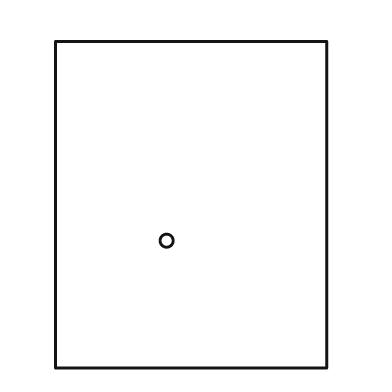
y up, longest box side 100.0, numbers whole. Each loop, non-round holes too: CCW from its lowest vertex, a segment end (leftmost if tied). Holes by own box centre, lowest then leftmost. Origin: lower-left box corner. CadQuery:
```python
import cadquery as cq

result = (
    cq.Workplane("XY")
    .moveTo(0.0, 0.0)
    .lineTo(83.0, 0.0)
    .lineTo(83.0, 100.0)
    .lineTo(0.0, 100.0)
    .close()
    .moveTo(34.0, 39.0)
    .circle(2.0)
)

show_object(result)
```